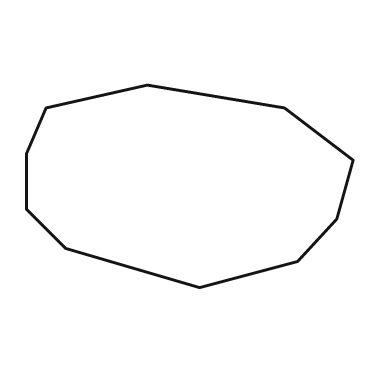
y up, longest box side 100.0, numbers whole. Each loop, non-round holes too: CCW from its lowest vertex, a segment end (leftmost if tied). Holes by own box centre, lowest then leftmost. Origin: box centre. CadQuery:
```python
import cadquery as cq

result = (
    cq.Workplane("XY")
    .moveTo(3.0, -31.0)
    .lineTo(33.0, -23.0)
    .lineTo(45.0, -10.0)
    .lineTo(50.0, 8.0)
    .lineTo(29.0, 24.0)
    .lineTo(-13.0, 31.0)
    .lineTo(-44.0, 24.0)
    .lineTo(-50.0, 10.0)
    .lineTo(-50.0, -7.0)
    .lineTo(-38.0, -19.0)
    .close()
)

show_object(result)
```